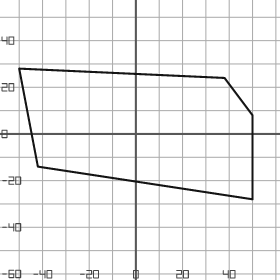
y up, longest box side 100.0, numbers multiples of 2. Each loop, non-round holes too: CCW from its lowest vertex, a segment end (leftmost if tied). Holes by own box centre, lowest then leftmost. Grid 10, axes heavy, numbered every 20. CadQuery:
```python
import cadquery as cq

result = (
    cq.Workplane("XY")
    .moveTo(50.0, -28.0)
    .lineTo(50.0, 8.0)
    .lineTo(38.0, 24.0)
    .lineTo(-50.0, 28.0)
    .lineTo(-42.0, -14.0)
    .close()
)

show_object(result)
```